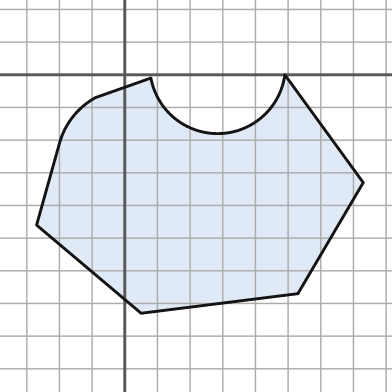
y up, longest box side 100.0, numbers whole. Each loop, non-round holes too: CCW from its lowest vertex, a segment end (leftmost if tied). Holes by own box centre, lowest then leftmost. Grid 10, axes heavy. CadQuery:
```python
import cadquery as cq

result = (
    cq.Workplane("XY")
    .moveTo(5.0, -73.0)
    .lineTo(53.0, -67.0)
    .lineTo(73.0, -33.0)
    .lineTo(49.0, 0.0)
    .threePointArc((29.0, -18.0), (8.0, -1.0))
    .lineTo(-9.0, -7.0)
    .threePointArc((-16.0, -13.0), (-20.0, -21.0))
    .lineTo(-27.0, -46.0)
    .close()
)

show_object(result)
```